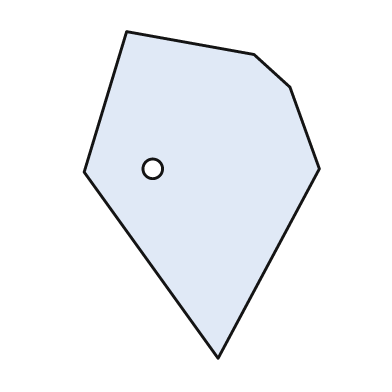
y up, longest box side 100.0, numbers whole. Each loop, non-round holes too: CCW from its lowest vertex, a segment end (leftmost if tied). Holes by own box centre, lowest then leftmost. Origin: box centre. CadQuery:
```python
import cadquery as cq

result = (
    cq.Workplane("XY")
    .moveTo(5.0, -50.0)
    .lineTo(36.0, 8.0)
    .lineTo(27.0, 33.0)
    .lineTo(16.0, 43.0)
    .lineTo(-23.0, 50.0)
    .lineTo(-36.0, 7.0)
    .close()
    .moveTo(-15.0, 8.0)
    .circle(3.0)
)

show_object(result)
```